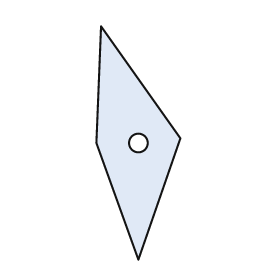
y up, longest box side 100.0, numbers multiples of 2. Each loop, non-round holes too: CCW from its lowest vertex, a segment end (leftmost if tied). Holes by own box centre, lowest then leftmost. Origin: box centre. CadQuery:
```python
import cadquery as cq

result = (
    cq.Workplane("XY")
    .moveTo(0.0, -50.0)
    .lineTo(18.0, 2.0)
    .lineTo(-16.0, 50.0)
    .lineTo(-18.0, 0.0)
    .close()
    .moveTo(0.0, 0.0)
    .circle(4.0)
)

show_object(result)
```